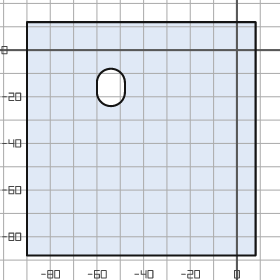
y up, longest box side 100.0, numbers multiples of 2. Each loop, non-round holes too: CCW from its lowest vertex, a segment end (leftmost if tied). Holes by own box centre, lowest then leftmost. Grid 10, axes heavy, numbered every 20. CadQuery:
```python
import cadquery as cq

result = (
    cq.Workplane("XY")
    .moveTo(-90.0, -88.0)
    .lineTo(8.0, -88.0)
    .lineTo(8.0, 12.0)
    .lineTo(-90.0, 12.0)
    .close()
    .moveTo(-60.0, -18.0)
    .threePointArc((-54.0, -24.0), (-48.0, -18.0))
    .lineTo(-48.0, -14.0)
    .threePointArc((-54.0, -8.0), (-60.0, -14.0))
    .close()
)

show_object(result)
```